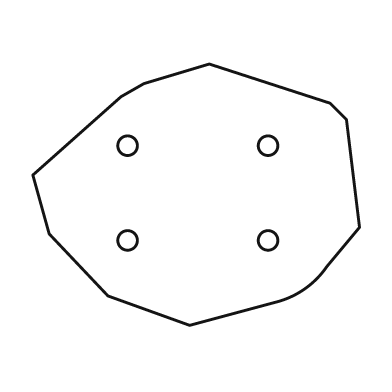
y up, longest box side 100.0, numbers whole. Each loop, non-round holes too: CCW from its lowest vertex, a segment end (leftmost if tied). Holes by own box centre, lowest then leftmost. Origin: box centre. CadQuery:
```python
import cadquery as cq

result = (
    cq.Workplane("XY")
    .moveTo(-2.0, -40.0)
    .lineTo(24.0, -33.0)
    .threePointArc((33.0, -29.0), (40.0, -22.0))
    .lineTo(50.0, -10.0)
    .lineTo(46.0, 23.0)
    .lineTo(41.0, 28.0)
    .lineTo(4.0, 40.0)
    .lineTo(-16.0, 34.0)
    .lineTo(-23.0, 30.0)
    .lineTo(-50.0, 6.0)
    .lineTo(-45.0, -12.0)
    .lineTo(-27.0, -31.0)
    .close()
    .moveTo(-21.0, -14.0)
    .circle(3.0)
    .moveTo(22.0, -14.0)
    .circle(3.0)
    .moveTo(-21.0, 15.0)
    .circle(3.0)
    .moveTo(22.0, 15.0)
    .circle(3.0)
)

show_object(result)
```